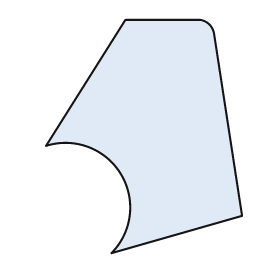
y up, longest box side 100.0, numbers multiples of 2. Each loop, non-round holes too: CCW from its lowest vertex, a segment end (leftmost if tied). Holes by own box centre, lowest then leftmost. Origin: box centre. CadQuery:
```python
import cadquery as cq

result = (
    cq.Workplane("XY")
    .moveTo(-14.0, -50.0)
    .lineTo(42.0, -34.0)
    .lineTo(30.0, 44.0)
    .threePointArc((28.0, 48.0), (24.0, 50.0))
    .lineTo(-8.0, 50.0)
    .lineTo(-42.0, -4.0)
    .threePointArc((-10.0, -16.0), (-14.0, -50.0))
    .close()
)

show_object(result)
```